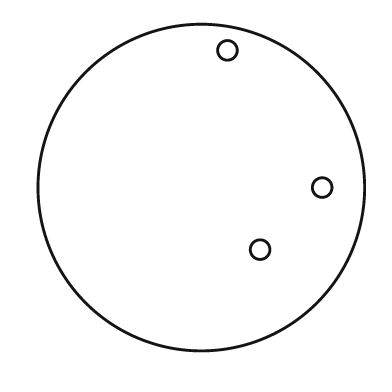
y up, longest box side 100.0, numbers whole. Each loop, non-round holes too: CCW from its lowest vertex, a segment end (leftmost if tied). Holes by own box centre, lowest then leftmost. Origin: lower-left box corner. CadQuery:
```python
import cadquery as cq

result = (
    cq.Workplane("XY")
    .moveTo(50.0, 50.0)
    .circle(50.0)
    .moveTo(68.0, 31.0)
    .circle(3.0)
    .moveTo(87.0, 50.0)
    .circle(3.0)
    .moveTo(58.0, 92.0)
    .circle(3.0)
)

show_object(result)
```